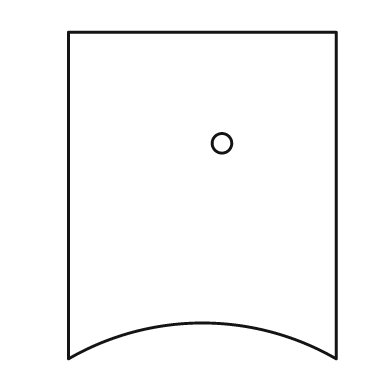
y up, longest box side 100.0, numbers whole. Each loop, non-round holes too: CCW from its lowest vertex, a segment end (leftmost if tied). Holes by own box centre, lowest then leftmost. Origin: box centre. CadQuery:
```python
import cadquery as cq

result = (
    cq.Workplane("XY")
    .moveTo(-41.0, -50.0)
    .threePointArc((0.0, -39.0), (41.0, -50.0))
    .lineTo(41.0, 50.0)
    .lineTo(-41.0, 50.0)
    .close()
    .moveTo(6.0, 16.0)
    .circle(3.0)
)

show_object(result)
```